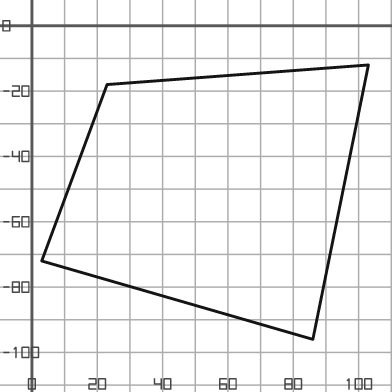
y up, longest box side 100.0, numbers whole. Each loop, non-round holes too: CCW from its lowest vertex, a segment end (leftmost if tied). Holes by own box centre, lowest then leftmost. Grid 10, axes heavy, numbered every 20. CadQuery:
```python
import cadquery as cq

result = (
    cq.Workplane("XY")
    .moveTo(86.0, -96.0)
    .lineTo(103.0, -12.0)
    .lineTo(23.0, -18.0)
    .lineTo(3.0, -72.0)
    .close()
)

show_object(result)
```